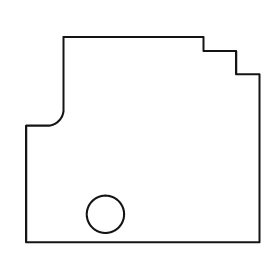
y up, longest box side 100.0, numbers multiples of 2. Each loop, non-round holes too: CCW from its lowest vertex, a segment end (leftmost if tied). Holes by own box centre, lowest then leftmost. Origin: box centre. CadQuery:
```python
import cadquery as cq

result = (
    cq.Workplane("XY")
    .moveTo(-50.0, -44.0)
    .lineTo(50.0, -44.0)
    .lineTo(50.0, 28.0)
    .lineTo(40.0, 28.0)
    .lineTo(40.0, 38.0)
    .lineTo(26.0, 38.0)
    .lineTo(26.0, 44.0)
    .lineTo(-34.0, 44.0)
    .lineTo(-34.0, 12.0)
    .threePointArc((-36.0, 8.0), (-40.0, 6.0))
    .lineTo(-50.0, 6.0)
    .close()
    .moveTo(-16.0, -32.0)
    .circle(8.0)
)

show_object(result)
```